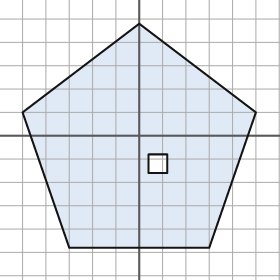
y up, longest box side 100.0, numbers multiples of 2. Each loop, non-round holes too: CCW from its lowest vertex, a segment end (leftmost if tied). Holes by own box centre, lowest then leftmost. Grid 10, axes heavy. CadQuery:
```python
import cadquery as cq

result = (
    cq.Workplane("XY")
    .moveTo(-30.0, -48.0)
    .lineTo(30.0, -48.0)
    .lineTo(50.0, 10.0)
    .lineTo(0.0, 48.0)
    .lineTo(-50.0, 10.0)
    .close()
    .moveTo(4.0, -16.0)
    .lineTo(12.0, -16.0)
    .lineTo(12.0, -8.0)
    .lineTo(4.0, -8.0)
    .close()
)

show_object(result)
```